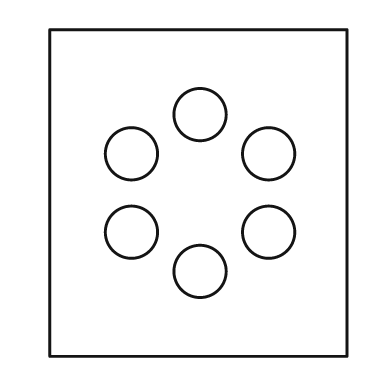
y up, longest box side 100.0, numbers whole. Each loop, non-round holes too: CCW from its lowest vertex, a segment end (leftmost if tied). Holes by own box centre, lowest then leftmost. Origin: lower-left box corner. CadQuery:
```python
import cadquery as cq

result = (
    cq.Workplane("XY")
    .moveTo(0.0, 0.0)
    .lineTo(91.0, 0.0)
    .lineTo(91.0, 100.0)
    .lineTo(0.0, 100.0)
    .close()
    .moveTo(46.0, 26.0)
    .circle(8.0)
    .moveTo(25.0, 38.0)
    .circle(8.0)
    .moveTo(67.0, 38.0)
    .circle(8.0)
    .moveTo(25.0, 62.0)
    .circle(8.0)
    .moveTo(67.0, 62.0)
    .circle(8.0)
    .moveTo(46.0, 74.0)
    .circle(8.0)
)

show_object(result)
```